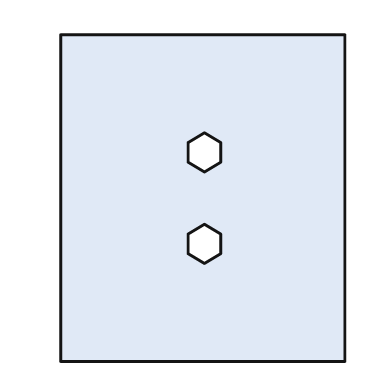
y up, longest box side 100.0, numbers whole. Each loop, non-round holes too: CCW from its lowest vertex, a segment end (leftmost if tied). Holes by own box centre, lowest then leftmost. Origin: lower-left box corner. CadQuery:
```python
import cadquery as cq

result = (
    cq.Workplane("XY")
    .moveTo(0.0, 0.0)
    .lineTo(87.0, 0.0)
    .lineTo(87.0, 100.0)
    .lineTo(0.0, 100.0)
    .close()
    .moveTo(44.0, 30.0)
    .lineTo(49.0, 33.0)
    .lineTo(49.0, 39.0)
    .lineTo(44.0, 42.0)
    .lineTo(39.0, 39.0)
    .lineTo(39.0, 33.0)
    .close()
    .moveTo(44.0, 58.0)
    .lineTo(49.0, 61.0)
    .lineTo(49.0, 67.0)
    .lineTo(44.0, 70.0)
    .lineTo(39.0, 67.0)
    .lineTo(39.0, 61.0)
    .close()
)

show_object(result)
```